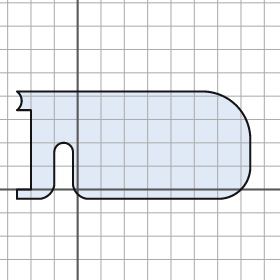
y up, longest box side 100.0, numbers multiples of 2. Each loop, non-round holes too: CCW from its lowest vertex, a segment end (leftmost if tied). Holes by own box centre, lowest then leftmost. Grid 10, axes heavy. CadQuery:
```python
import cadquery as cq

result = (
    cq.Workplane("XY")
    .moveTo(-26.0, -4.0)
    .lineTo(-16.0, -4.0)
    .threePointArc((-12.0, -2.0), (-10.0, 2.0))
    .lineTo(-10.0, 16.0)
    .threePointArc((-6.0, 20.0), (-2.0, 16.0))
    .lineTo(-2.0, 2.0)
    .threePointArc((0.0, -2.0), (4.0, -4.0))
    .lineTo(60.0, -4.0)
    .threePointArc((70.0, 0.0), (74.0, 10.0))
    .lineTo(74.0, 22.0)
    .threePointArc((68.0, 36.0), (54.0, 42.0))
    .lineTo(-26.0, 42.0)
    .threePointArc((-24.0, 38.0), (-26.0, 34.0))
    .lineTo(-20.0, 34.0)
    .lineTo(-20.0, 0.0)
    .lineTo(-26.0, 0.0)
    .close()
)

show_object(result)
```